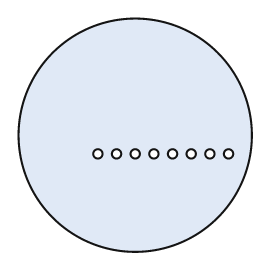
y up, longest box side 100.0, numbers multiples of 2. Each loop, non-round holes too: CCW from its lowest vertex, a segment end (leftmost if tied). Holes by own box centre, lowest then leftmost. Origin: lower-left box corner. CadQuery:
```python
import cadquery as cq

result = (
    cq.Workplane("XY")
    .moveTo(50.0, 50.0)
    .circle(50.0)
    .moveTo(34.0, 42.0)
    .circle(2.0)
    .moveTo(42.0, 42.0)
    .circle(2.0)
    .moveTo(50.0, 42.0)
    .circle(2.0)
    .moveTo(58.0, 42.0)
    .circle(2.0)
    .moveTo(66.0, 42.0)
    .circle(2.0)
    .moveTo(74.0, 42.0)
    .circle(2.0)
    .moveTo(82.0, 42.0)
    .circle(2.0)
    .moveTo(90.0, 42.0)
    .circle(2.0)
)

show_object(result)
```